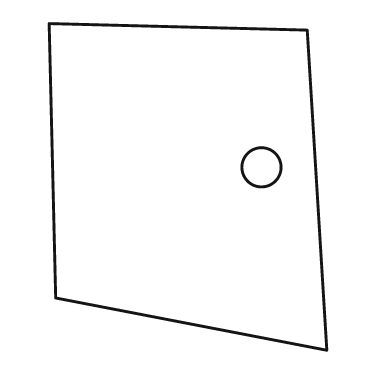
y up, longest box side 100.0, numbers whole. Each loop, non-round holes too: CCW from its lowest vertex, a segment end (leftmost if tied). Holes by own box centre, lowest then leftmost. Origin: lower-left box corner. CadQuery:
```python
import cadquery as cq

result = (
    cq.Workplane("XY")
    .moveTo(85.0, 0.0)
    .lineTo(79.0, 98.0)
    .lineTo(0.0, 100.0)
    .lineTo(2.0, 16.0)
    .close()
    .moveTo(65.0, 56.0)
    .circle(6.0)
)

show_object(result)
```